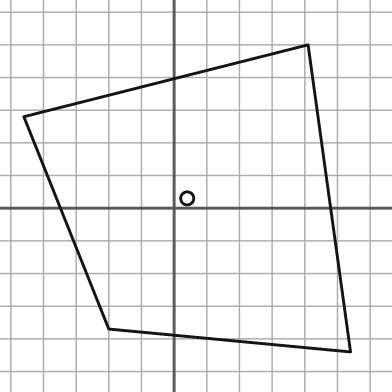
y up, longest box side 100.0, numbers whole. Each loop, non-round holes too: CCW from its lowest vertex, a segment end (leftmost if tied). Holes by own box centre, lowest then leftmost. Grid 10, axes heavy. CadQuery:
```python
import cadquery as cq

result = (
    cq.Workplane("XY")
    .moveTo(54.0, -44.0)
    .lineTo(41.0, 50.0)
    .lineTo(-46.0, 28.0)
    .lineTo(-20.0, -37.0)
    .close()
    .moveTo(4.0, 3.0)
    .circle(2.0)
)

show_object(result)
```